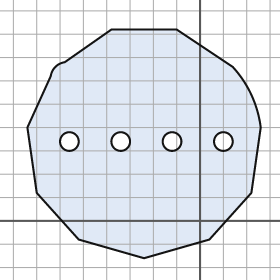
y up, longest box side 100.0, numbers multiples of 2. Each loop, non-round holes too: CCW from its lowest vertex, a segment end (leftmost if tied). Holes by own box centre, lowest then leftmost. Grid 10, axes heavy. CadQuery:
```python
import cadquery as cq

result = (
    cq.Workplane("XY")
    .moveTo(-24.0, -16.0)
    .lineTo(4.0, -8.0)
    .lineTo(22.0, 12.0)
    .lineTo(26.0, 40.0)
    .threePointArc((22.0, 54.0), (14.0, 66.0))
    .lineTo(-10.0, 82.0)
    .lineTo(-38.0, 82.0)
    .lineTo(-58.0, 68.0)
    .threePointArc((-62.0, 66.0), (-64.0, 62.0))
    .lineTo(-74.0, 40.0)
    .lineTo(-70.0, 12.0)
    .lineTo(-52.0, -8.0)
    .close()
    .moveTo(-56.0, 34.0)
    .circle(4.0)
    .moveTo(-34.0, 34.0)
    .circle(4.0)
    .moveTo(-12.0, 34.0)
    .circle(4.0)
    .moveTo(10.0, 34.0)
    .circle(4.0)
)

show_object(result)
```